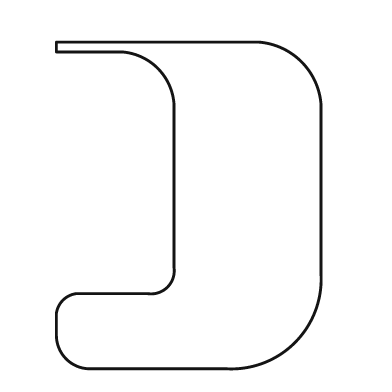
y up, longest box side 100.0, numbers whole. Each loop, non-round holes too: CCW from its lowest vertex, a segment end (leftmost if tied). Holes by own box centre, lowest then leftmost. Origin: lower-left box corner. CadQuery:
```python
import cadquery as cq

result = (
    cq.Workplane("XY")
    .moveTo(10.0, 0.0)
    .lineTo(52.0, 0.0)
    .threePointArc((73.0, 8.0), (81.0, 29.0))
    .lineTo(81.0, 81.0)
    .threePointArc((75.0, 94.0), (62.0, 100.0))
    .lineTo(0.0, 100.0)
    .lineTo(0.0, 97.0)
    .lineTo(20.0, 97.0)
    .threePointArc((31.0, 92.0), (36.0, 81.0))
    .lineTo(36.0, 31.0)
    .threePointArc((34.0, 25.0), (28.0, 23.0))
    .lineTo(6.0, 23.0)
    .threePointArc((2.0, 21.0), (0.0, 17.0))
    .lineTo(0.0, 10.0)
    .threePointArc((3.0, 3.0), (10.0, 0.0))
    .close()
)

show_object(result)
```